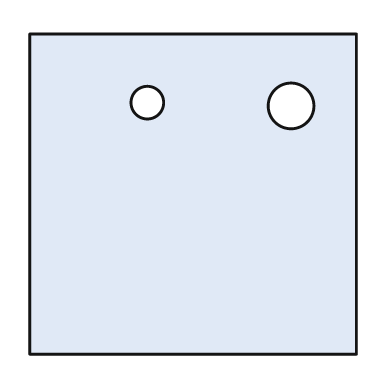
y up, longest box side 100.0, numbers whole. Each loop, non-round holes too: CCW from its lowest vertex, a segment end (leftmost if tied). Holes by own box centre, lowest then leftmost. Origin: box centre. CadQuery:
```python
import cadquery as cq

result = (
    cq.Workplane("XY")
    .moveTo(-50.0, -49.0)
    .lineTo(50.0, -49.0)
    .lineTo(50.0, 49.0)
    .lineTo(-50.0, 49.0)
    .close()
    .moveTo(30.0, 27.0)
    .circle(7.0)
    .moveTo(-14.0, 28.0)
    .circle(5.0)
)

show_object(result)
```